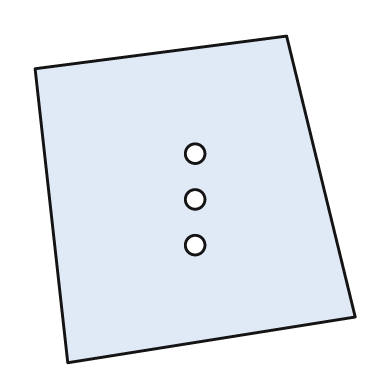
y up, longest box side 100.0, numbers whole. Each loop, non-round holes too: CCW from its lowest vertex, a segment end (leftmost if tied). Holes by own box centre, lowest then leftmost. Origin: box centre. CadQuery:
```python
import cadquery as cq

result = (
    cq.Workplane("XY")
    .moveTo(-39.0, -50.0)
    .lineTo(49.0, -36.0)
    .lineTo(28.0, 50.0)
    .lineTo(-49.0, 40.0)
    .close()
    .moveTo(0.0, -14.0)
    .circle(3.0)
    .moveTo(0.0, 0.0)
    .circle(3.0)
    .moveTo(0.0, 14.0)
    .circle(3.0)
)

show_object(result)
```